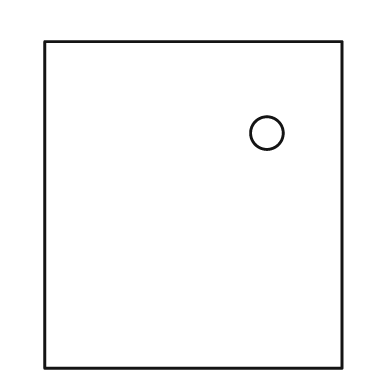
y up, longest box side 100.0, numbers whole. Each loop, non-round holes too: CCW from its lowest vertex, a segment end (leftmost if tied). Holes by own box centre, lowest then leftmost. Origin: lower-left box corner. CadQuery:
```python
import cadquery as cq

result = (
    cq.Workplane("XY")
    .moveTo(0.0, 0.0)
    .lineTo(91.0, 0.0)
    .lineTo(91.0, 100.0)
    .lineTo(0.0, 100.0)
    .close()
    .moveTo(68.0, 72.0)
    .circle(5.0)
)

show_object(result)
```